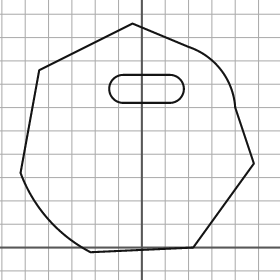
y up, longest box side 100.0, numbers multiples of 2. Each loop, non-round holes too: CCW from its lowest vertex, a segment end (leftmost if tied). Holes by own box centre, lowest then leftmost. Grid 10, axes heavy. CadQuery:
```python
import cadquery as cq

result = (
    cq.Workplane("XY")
    .moveTo(-22.0, -2.0)
    .lineTo(22.0, 0.0)
    .lineTo(48.0, 36.0)
    .lineTo(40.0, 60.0)
    .threePointArc((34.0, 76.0), (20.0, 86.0))
    .lineTo(-4.0, 96.0)
    .lineTo(-44.0, 76.0)
    .lineTo(-52.0, 32.0)
    .threePointArc((-40.0, 12.0), (-22.0, -2.0))
    .close()
    .moveTo(-8.0, 62.0)
    .lineTo(12.0, 62.0)
    .threePointArc((18.0, 68.0), (12.0, 74.0))
    .lineTo(-8.0, 74.0)
    .threePointArc((-14.0, 68.0), (-8.0, 62.0))
    .close()
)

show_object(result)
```